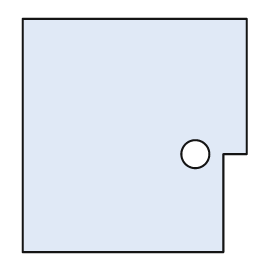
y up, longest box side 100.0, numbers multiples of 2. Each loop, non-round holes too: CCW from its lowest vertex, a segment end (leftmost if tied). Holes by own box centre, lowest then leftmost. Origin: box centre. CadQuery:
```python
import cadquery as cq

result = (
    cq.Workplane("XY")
    .moveTo(-48.0, -50.0)
    .lineTo(38.0, -50.0)
    .lineTo(38.0, -8.0)
    .lineTo(48.0, -8.0)
    .lineTo(48.0, 50.0)
    .lineTo(-48.0, 50.0)
    .close()
    .moveTo(26.0, -8.0)
    .circle(6.0)
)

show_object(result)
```